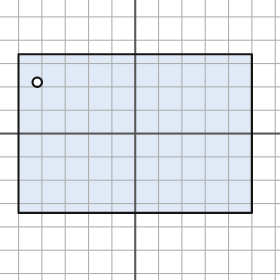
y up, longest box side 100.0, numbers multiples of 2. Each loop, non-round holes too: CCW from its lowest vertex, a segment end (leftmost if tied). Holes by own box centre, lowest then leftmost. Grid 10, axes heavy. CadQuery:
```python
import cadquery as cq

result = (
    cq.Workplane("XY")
    .moveTo(-50.0, -34.0)
    .lineTo(50.0, -34.0)
    .lineTo(50.0, 34.0)
    .lineTo(-50.0, 34.0)
    .close()
    .moveTo(-42.0, 22.0)
    .circle(2.0)
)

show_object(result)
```